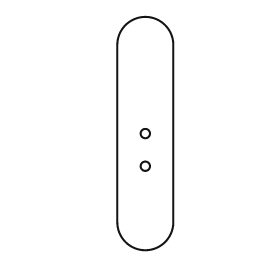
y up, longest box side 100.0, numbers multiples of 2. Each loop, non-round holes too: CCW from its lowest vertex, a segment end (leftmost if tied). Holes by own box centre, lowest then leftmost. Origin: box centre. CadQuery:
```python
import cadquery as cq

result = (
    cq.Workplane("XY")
    .moveTo(-12.0, -38.0)
    .threePointArc((0.0, -50.0), (12.0, -38.0))
    .lineTo(12.0, 38.0)
    .threePointArc((0.0, 50.0), (-12.0, 38.0))
    .close()
    .moveTo(0.0, -14.0)
    .circle(2.0)
    .moveTo(0.0, 0.0)
    .circle(2.0)
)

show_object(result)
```